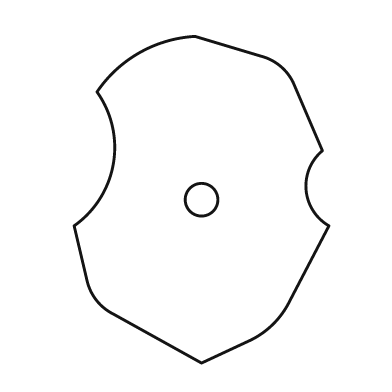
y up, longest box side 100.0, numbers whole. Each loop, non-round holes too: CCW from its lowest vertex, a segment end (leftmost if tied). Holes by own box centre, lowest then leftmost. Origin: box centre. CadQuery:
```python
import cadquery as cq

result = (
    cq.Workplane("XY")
    .moveTo(0.0, -50.0)
    .lineTo(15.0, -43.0)
    .threePointArc((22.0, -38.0), (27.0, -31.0))
    .lineTo(39.0, -8.0)
    .threePointArc((32.0, 3.0), (37.0, 15.0))
    .lineTo(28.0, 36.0)
    .threePointArc((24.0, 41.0), (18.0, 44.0))
    .lineTo(-2.0, 50.0)
    .threePointArc((-19.0, 45.0), (-32.0, 33.0))
    .threePointArc((-27.0, 11.0), (-39.0, -8.0))
    .lineTo(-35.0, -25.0)
    .threePointArc((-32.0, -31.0), (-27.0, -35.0))
    .close()
    .moveTo(0.0, 0.0)
    .circle(5.0)
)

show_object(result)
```